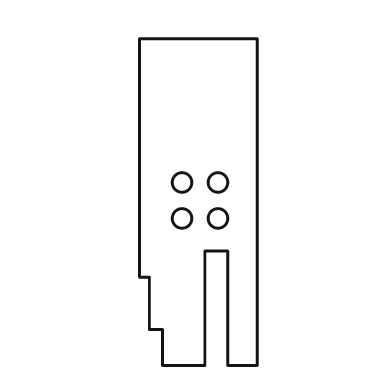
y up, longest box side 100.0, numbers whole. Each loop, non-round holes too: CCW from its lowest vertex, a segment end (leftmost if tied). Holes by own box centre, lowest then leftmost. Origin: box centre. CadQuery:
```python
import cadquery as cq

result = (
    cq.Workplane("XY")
    .moveTo(-11.0, -50.0)
    .lineTo(2.0, -50.0)
    .lineTo(2.0, -15.0)
    .lineTo(9.0, -15.0)
    .lineTo(9.0, -50.0)
    .lineTo(18.0, -50.0)
    .lineTo(18.0, 50.0)
    .lineTo(-18.0, 50.0)
    .lineTo(-18.0, -23.0)
    .lineTo(-15.0, -23.0)
    .lineTo(-15.0, -39.0)
    .lineTo(-11.0, -39.0)
    .close()
    .moveTo(-5.0, -5.0)
    .circle(3.0)
    .moveTo(6.0, -5.0)
    .circle(3.0)
    .moveTo(-5.0, 6.0)
    .circle(3.0)
    .moveTo(6.0, 6.0)
    .circle(3.0)
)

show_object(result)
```